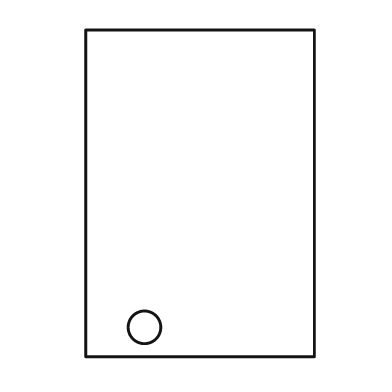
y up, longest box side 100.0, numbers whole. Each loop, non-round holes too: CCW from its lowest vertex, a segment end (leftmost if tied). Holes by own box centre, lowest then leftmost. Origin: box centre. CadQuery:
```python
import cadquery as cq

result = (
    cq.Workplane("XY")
    .moveTo(-35.0, -50.0)
    .lineTo(35.0, -50.0)
    .lineTo(35.0, 50.0)
    .lineTo(-35.0, 50.0)
    .close()
    .moveTo(-17.0, -41.0)
    .circle(5.0)
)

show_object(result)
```